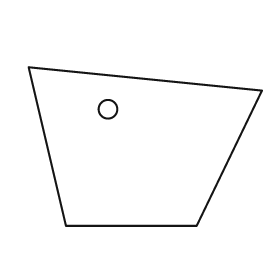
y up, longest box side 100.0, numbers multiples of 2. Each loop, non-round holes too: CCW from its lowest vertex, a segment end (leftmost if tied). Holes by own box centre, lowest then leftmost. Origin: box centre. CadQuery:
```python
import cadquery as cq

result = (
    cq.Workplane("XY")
    .moveTo(-34.0, -34.0)
    .lineTo(22.0, -34.0)
    .lineTo(50.0, 24.0)
    .lineTo(-50.0, 34.0)
    .close()
    .moveTo(-16.0, 16.0)
    .circle(4.0)
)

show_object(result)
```